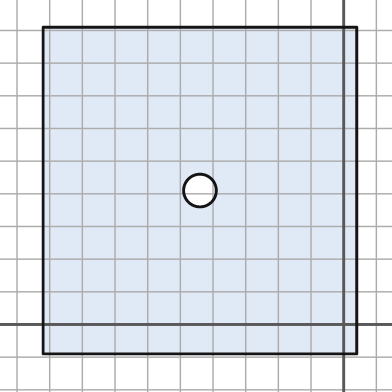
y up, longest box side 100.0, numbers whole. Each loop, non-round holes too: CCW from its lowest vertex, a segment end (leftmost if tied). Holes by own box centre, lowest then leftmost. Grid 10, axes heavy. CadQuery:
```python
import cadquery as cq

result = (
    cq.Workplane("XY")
    .moveTo(-92.0, -9.0)
    .lineTo(4.0, -9.0)
    .lineTo(4.0, 91.0)
    .lineTo(-92.0, 91.0)
    .close()
    .moveTo(-44.0, 41.0)
    .circle(5.0)
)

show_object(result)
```